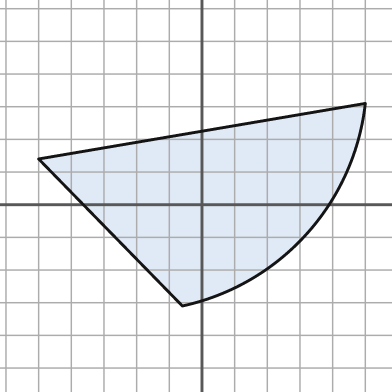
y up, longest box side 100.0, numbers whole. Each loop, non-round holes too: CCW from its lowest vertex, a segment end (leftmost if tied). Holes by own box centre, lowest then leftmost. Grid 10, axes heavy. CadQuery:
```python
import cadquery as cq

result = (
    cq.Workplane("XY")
    .moveTo(-6.0, -31.0)
    .threePointArc((32.0, -9.0), (50.0, 31.0))
    .lineTo(-50.0, 14.0)
    .close()
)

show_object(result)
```